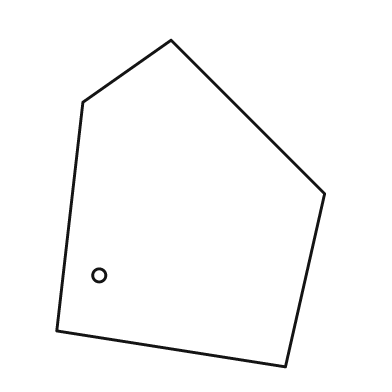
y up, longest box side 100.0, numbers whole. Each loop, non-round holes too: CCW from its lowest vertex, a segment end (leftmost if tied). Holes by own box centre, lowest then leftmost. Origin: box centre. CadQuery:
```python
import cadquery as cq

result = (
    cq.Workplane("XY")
    .moveTo(29.0, -50.0)
    .lineTo(41.0, 3.0)
    .lineTo(-6.0, 50.0)
    .lineTo(-33.0, 31.0)
    .lineTo(-41.0, -39.0)
    .close()
    .moveTo(-28.0, -22.0)
    .circle(2.0)
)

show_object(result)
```